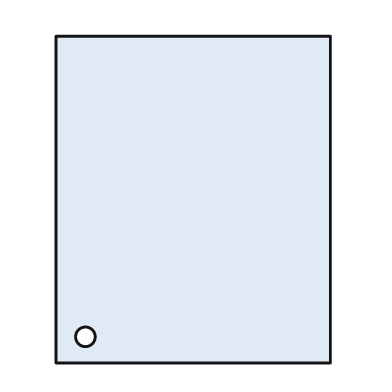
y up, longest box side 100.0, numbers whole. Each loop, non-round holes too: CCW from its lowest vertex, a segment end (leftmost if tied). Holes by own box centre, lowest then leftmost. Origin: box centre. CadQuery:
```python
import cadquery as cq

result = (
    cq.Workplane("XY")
    .moveTo(-42.0, -50.0)
    .lineTo(42.0, -50.0)
    .lineTo(42.0, 50.0)
    .lineTo(-42.0, 50.0)
    .close()
    .moveTo(-33.0, -42.0)
    .circle(3.0)
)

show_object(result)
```